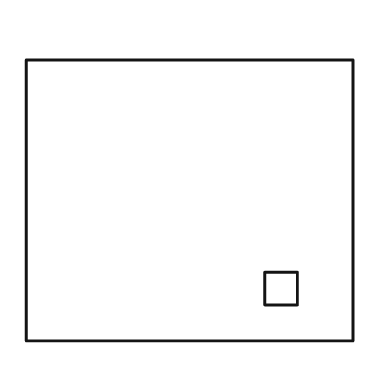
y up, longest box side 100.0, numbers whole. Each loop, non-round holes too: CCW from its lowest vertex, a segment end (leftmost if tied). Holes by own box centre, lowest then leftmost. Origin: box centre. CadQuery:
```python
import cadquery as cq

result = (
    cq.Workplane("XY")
    .moveTo(-50.0, -43.0)
    .lineTo(50.0, -43.0)
    .lineTo(50.0, 43.0)
    .lineTo(-50.0, 43.0)
    .close()
    .moveTo(23.0, -32.0)
    .lineTo(33.0, -32.0)
    .lineTo(33.0, -22.0)
    .lineTo(23.0, -22.0)
    .close()
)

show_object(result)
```